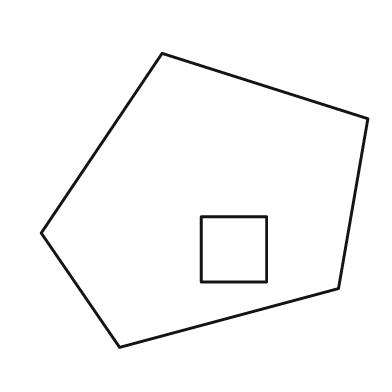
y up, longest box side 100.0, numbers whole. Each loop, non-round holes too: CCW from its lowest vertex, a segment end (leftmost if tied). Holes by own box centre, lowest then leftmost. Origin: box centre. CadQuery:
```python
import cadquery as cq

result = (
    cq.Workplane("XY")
    .moveTo(-26.0, -45.0)
    .lineTo(41.0, -27.0)
    .lineTo(50.0, 25.0)
    .lineTo(-13.0, 45.0)
    .lineTo(-50.0, -10.0)
    .close()
    .moveTo(-1.0, -25.0)
    .lineTo(19.0, -25.0)
    .lineTo(19.0, -5.0)
    .lineTo(-1.0, -5.0)
    .close()
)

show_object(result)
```